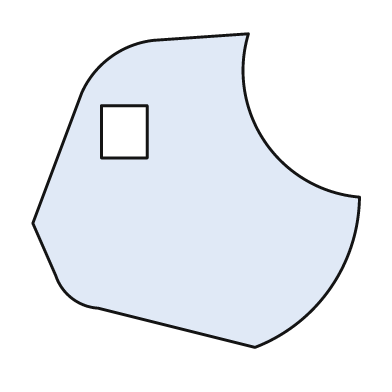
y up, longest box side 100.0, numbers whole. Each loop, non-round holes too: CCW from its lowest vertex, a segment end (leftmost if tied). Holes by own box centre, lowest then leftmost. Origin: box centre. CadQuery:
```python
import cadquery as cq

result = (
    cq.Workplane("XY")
    .moveTo(18.0, -48.0)
    .threePointArc((41.0, -30.0), (50.0, -2.0))
    .threePointArc((21.0, 15.0), (16.0, 48.0))
    .lineTo(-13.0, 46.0)
    .threePointArc((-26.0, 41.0), (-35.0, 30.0))
    .lineTo(-50.0, -10.0)
    .lineTo(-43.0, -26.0)
    .threePointArc((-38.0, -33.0), (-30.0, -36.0))
    .close()
    .moveTo(-29.0, 10.0)
    .lineTo(-15.0, 10.0)
    .lineTo(-15.0, 26.0)
    .lineTo(-29.0, 26.0)
    .close()
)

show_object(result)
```